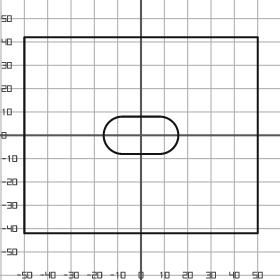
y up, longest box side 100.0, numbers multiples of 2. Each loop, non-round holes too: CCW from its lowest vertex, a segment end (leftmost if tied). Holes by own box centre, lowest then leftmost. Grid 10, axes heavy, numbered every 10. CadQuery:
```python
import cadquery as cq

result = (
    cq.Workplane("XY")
    .moveTo(-50.0, -42.0)
    .lineTo(50.0, -42.0)
    .lineTo(50.0, 42.0)
    .lineTo(-50.0, 42.0)
    .close()
    .moveTo(-8.0, -8.0)
    .lineTo(8.0, -8.0)
    .threePointArc((16.0, 0.0), (8.0, 8.0))
    .lineTo(-8.0, 8.0)
    .threePointArc((-16.0, 0.0), (-8.0, -8.0))
    .close()
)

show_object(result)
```